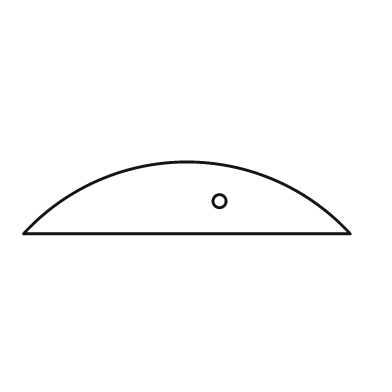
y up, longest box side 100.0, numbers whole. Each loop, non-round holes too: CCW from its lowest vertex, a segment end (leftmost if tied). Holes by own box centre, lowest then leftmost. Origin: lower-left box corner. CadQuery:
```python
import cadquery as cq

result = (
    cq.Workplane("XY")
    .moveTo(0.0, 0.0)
    .lineTo(100.0, 0.0)
    .threePointArc((50.0, 22.0), (0.0, 0.0))
    .close()
    .moveTo(60.0, 10.0)
    .circle(2.0)
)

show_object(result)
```